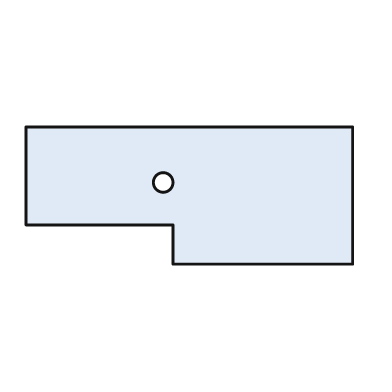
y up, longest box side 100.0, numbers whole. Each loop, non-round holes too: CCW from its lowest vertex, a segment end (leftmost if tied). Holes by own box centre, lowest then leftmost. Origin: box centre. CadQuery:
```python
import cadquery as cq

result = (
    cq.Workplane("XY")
    .moveTo(-5.0, -21.0)
    .lineTo(50.0, -21.0)
    .lineTo(50.0, 21.0)
    .lineTo(-50.0, 21.0)
    .lineTo(-50.0, -9.0)
    .lineTo(-5.0, -9.0)
    .close()
    .moveTo(-8.0, 4.0)
    .circle(3.0)
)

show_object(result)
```